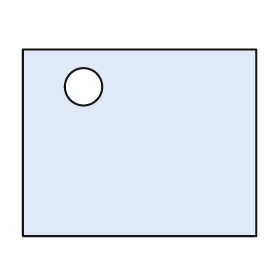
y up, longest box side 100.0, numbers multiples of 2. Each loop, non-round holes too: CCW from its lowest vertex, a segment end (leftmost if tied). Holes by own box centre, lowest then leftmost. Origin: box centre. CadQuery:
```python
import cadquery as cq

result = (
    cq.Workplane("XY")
    .moveTo(-50.0, -40.0)
    .lineTo(50.0, -40.0)
    .lineTo(50.0, 40.0)
    .lineTo(-50.0, 40.0)
    .close()
    .moveTo(-24.0, 24.0)
    .circle(8.0)
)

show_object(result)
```